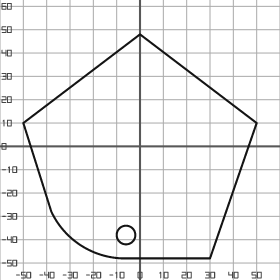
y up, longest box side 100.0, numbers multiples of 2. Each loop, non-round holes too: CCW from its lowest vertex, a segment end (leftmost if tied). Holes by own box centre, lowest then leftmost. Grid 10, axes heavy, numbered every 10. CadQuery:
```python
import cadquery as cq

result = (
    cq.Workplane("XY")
    .moveTo(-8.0, -48.0)
    .lineTo(30.0, -48.0)
    .lineTo(50.0, 10.0)
    .lineTo(0.0, 48.0)
    .lineTo(-50.0, 10.0)
    .lineTo(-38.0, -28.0)
    .threePointArc((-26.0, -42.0), (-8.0, -48.0))
    .close()
    .moveTo(-6.0, -38.0)
    .circle(4.0)
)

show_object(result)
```